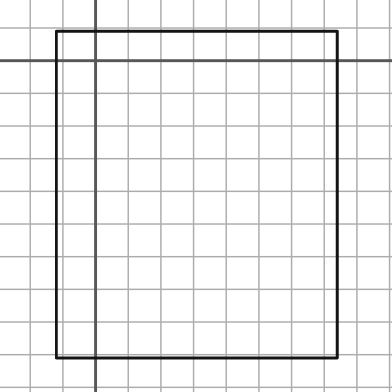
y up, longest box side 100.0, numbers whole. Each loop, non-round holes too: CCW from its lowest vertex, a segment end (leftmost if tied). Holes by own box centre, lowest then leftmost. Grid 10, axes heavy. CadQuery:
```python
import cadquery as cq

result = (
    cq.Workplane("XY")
    .moveTo(-12.0, -91.0)
    .lineTo(74.0, -91.0)
    .lineTo(74.0, 9.0)
    .lineTo(-12.0, 9.0)
    .close()
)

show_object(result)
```